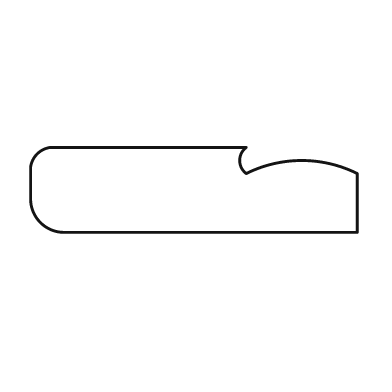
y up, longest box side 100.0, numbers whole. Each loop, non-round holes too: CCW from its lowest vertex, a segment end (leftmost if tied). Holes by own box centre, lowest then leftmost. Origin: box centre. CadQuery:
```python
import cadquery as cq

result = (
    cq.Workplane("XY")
    .moveTo(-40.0, -13.0)
    .lineTo(50.0, -13.0)
    .lineTo(50.0, 5.0)
    .threePointArc((33.0, 9.0), (16.0, 5.0))
    .threePointArc((14.0, 9.0), (16.0, 13.0))
    .lineTo(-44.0, 13.0)
    .threePointArc((-48.0, 11.0), (-50.0, 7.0))
    .lineTo(-50.0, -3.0)
    .threePointArc((-47.0, -10.0), (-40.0, -13.0))
    .close()
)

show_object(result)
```